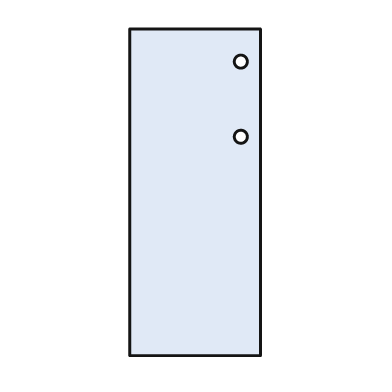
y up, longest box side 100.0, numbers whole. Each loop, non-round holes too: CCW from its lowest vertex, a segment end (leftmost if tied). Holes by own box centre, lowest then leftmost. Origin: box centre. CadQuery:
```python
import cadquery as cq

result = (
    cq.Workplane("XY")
    .moveTo(-20.0, -50.0)
    .lineTo(20.0, -50.0)
    .lineTo(20.0, 50.0)
    .lineTo(-20.0, 50.0)
    .close()
    .moveTo(14.0, 17.0)
    .circle(2.0)
    .moveTo(14.0, 40.0)
    .circle(2.0)
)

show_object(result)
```